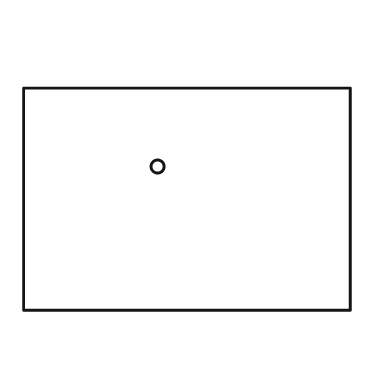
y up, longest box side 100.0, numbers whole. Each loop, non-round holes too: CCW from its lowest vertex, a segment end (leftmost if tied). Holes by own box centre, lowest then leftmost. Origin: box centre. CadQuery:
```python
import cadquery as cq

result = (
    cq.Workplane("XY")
    .moveTo(-50.0, -34.0)
    .lineTo(50.0, -34.0)
    .lineTo(50.0, 34.0)
    .lineTo(-50.0, 34.0)
    .close()
    .moveTo(-9.0, 10.0)
    .circle(2.0)
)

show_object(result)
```